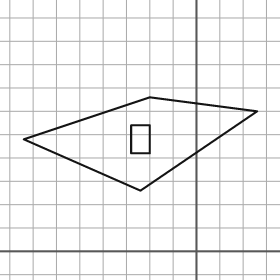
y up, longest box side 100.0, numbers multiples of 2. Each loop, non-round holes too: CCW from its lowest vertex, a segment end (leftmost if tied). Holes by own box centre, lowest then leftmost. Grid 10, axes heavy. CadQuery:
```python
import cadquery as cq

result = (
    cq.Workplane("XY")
    .moveTo(-24.0, 26.0)
    .lineTo(26.0, 60.0)
    .lineTo(-20.0, 66.0)
    .lineTo(-74.0, 48.0)
    .close()
    .moveTo(-28.0, 42.0)
    .lineTo(-20.0, 42.0)
    .lineTo(-20.0, 54.0)
    .lineTo(-28.0, 54.0)
    .close()
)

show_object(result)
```